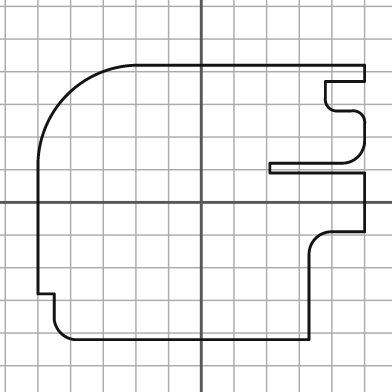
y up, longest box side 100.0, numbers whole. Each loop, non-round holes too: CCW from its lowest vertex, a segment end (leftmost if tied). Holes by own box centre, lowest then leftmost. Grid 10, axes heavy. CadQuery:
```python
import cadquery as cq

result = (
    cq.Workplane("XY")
    .moveTo(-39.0, -42.0)
    .lineTo(33.0, -42.0)
    .lineTo(33.0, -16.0)
    .threePointArc((35.0, -11.0), (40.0, -9.0))
    .lineTo(50.0, -9.0)
    .lineTo(50.0, 9.0)
    .lineTo(21.0, 9.0)
    .lineTo(21.0, 12.0)
    .lineTo(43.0, 12.0)
    .threePointArc((48.0, 14.0), (50.0, 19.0))
    .lineTo(50.0, 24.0)
    .threePointArc((49.0, 27.0), (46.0, 28.0))
    .lineTo(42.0, 28.0)
    .threePointArc((39.0, 29.0), (38.0, 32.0))
    .lineTo(38.0, 37.0)
    .lineTo(50.0, 37.0)
    .lineTo(50.0, 42.0)
    .lineTo(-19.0, 42.0)
    .threePointArc((-41.0, 33.0), (-50.0, 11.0))
    .lineTo(-50.0, -28.0)
    .lineTo(-45.0, -28.0)
    .lineTo(-45.0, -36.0)
    .threePointArc((-43.0, -40.0), (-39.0, -42.0))
    .close()
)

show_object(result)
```